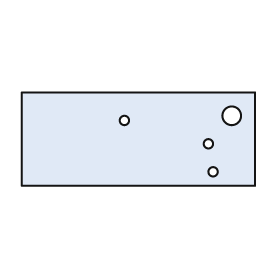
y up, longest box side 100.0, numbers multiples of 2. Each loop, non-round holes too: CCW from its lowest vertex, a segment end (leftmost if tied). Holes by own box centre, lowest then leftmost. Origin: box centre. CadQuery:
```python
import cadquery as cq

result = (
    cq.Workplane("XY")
    .moveTo(-50.0, -20.0)
    .lineTo(50.0, -20.0)
    .lineTo(50.0, 20.0)
    .lineTo(-50.0, 20.0)
    .close()
    .moveTo(32.0, -14.0)
    .circle(2.0)
    .moveTo(30.0, -2.0)
    .circle(2.0)
    .moveTo(-6.0, 8.0)
    .circle(2.0)
    .moveTo(40.0, 10.0)
    .circle(4.0)
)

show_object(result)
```